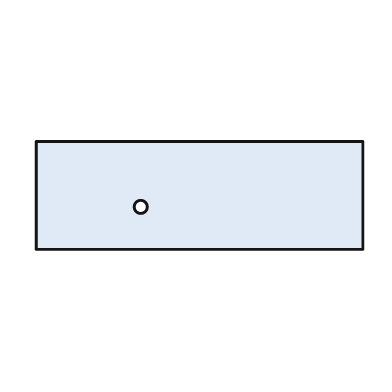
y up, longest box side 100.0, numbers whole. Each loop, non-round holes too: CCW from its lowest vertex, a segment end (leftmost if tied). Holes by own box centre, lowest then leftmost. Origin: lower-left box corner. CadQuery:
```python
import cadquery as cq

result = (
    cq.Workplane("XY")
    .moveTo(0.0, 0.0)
    .lineTo(100.0, 0.0)
    .lineTo(100.0, 33.0)
    .lineTo(0.0, 33.0)
    .close()
    .moveTo(32.0, 13.0)
    .circle(2.0)
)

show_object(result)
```